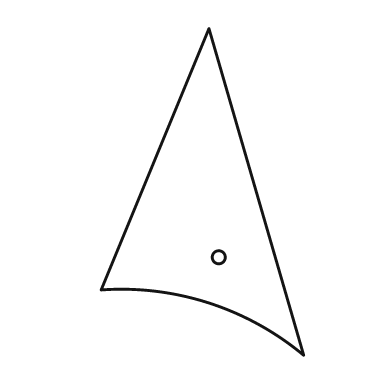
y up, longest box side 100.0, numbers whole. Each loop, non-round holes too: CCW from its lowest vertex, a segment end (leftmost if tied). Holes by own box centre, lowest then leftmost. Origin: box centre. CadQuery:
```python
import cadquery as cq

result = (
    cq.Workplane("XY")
    .moveTo(31.0, -50.0)
    .lineTo(2.0, 50.0)
    .lineTo(-31.0, -30.0)
    .threePointArc((2.0, -34.0), (31.0, -50.0))
    .close()
    .moveTo(5.0, -20.0)
    .circle(2.0)
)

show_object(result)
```